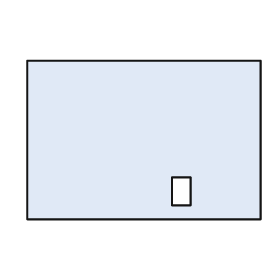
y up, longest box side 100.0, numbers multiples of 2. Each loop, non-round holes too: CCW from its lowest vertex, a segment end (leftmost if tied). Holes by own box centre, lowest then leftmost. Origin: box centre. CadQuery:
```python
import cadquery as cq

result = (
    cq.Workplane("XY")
    .moveTo(-50.0, -34.0)
    .lineTo(50.0, -34.0)
    .lineTo(50.0, 34.0)
    .lineTo(-50.0, 34.0)
    .close()
    .moveTo(12.0, -28.0)
    .lineTo(20.0, -28.0)
    .lineTo(20.0, -16.0)
    .lineTo(12.0, -16.0)
    .close()
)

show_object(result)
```